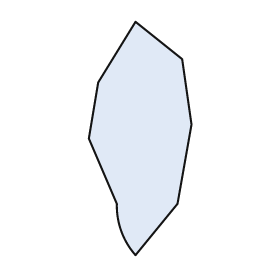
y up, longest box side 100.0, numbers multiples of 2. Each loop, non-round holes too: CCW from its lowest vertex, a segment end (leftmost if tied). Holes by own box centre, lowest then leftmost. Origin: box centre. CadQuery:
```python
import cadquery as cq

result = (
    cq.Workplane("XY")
    .moveTo(-2.0, -50.0)
    .lineTo(16.0, -28.0)
    .lineTo(22.0, 6.0)
    .lineTo(18.0, 34.0)
    .lineTo(-2.0, 50.0)
    .lineTo(-18.0, 24.0)
    .lineTo(-22.0, 0.0)
    .lineTo(-10.0, -28.0)
    .threePointArc((-8.0, -40.0), (-2.0, -50.0))
    .close()
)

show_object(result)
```